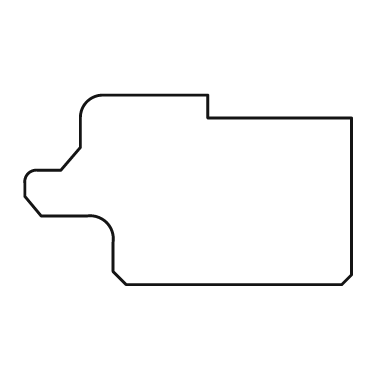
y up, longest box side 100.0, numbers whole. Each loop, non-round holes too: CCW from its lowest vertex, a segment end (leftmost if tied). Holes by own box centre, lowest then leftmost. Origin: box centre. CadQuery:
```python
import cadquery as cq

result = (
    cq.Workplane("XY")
    .moveTo(-19.0, -29.0)
    .lineTo(47.0, -29.0)
    .lineTo(50.0, -26.0)
    .lineTo(50.0, 22.0)
    .lineTo(6.0, 22.0)
    .lineTo(6.0, 29.0)
    .lineTo(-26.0, 29.0)
    .threePointArc((-31.0, 27.0), (-33.0, 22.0))
    .lineTo(-33.0, 13.0)
    .lineTo(-39.0, 6.0)
    .lineTo(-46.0, 6.0)
    .threePointArc((-49.0, 5.0), (-50.0, 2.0))
    .lineTo(-50.0, -2.0)
    .lineTo(-45.0, -8.0)
    .lineTo(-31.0, -8.0)
    .threePointArc((-25.0, -10.0), (-23.0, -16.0))
    .lineTo(-23.0, -25.0)
    .close()
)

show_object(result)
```